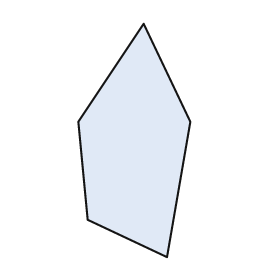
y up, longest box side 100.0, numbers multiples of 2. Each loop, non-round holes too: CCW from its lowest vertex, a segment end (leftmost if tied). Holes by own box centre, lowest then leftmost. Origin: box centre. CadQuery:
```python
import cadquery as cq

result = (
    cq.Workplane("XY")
    .moveTo(14.0, -50.0)
    .lineTo(24.0, 8.0)
    .lineTo(4.0, 50.0)
    .lineTo(-24.0, 8.0)
    .lineTo(-20.0, -34.0)
    .close()
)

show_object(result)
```